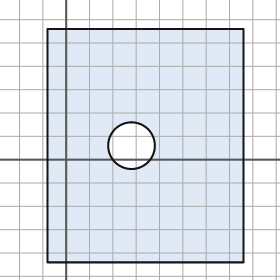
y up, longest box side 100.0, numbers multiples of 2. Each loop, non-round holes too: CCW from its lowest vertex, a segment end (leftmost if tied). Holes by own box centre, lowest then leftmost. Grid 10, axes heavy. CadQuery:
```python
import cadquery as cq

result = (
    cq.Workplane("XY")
    .moveTo(-8.0, -44.0)
    .lineTo(76.0, -44.0)
    .lineTo(76.0, 56.0)
    .lineTo(-8.0, 56.0)
    .close()
    .moveTo(28.0, 6.0)
    .circle(10.0)
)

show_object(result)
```